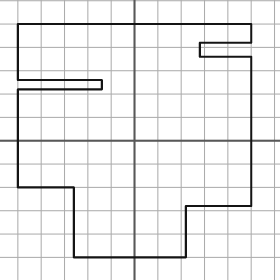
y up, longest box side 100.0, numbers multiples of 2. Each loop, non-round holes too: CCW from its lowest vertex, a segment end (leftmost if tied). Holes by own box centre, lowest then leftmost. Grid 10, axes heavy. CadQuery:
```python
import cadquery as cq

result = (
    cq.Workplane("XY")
    .moveTo(-26.0, -50.0)
    .lineTo(22.0, -50.0)
    .lineTo(22.0, -28.0)
    .lineTo(50.0, -28.0)
    .lineTo(50.0, 36.0)
    .lineTo(28.0, 36.0)
    .lineTo(28.0, 42.0)
    .lineTo(50.0, 42.0)
    .lineTo(50.0, 50.0)
    .lineTo(-50.0, 50.0)
    .lineTo(-50.0, 26.0)
    .lineTo(-14.0, 26.0)
    .lineTo(-14.0, 22.0)
    .lineTo(-50.0, 22.0)
    .lineTo(-50.0, -20.0)
    .lineTo(-26.0, -20.0)
    .close()
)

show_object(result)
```